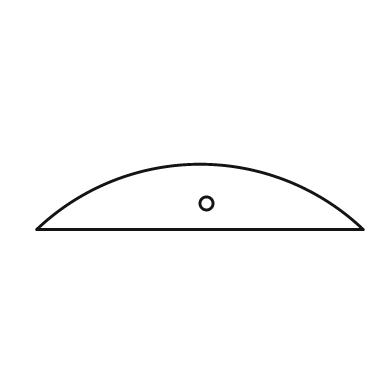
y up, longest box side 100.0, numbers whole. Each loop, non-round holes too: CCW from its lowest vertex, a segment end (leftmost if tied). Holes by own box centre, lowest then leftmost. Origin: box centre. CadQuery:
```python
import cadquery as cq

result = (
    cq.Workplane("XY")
    .moveTo(-50.0, -10.0)
    .lineTo(50.0, -10.0)
    .threePointArc((0.0, 10.0), (-50.0, -10.0))
    .close()
    .moveTo(2.0, -2.0)
    .circle(2.0)
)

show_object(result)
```